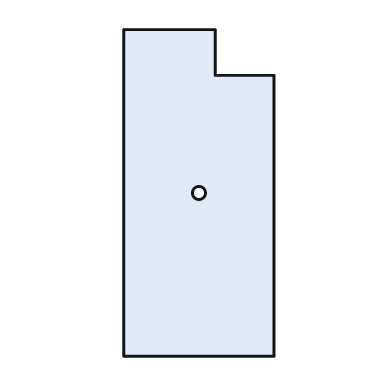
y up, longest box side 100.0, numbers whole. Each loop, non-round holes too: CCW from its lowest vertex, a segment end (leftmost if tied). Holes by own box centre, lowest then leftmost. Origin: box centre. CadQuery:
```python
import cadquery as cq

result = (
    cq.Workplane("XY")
    .moveTo(-23.0, -50.0)
    .lineTo(23.0, -50.0)
    .lineTo(23.0, 36.0)
    .lineTo(5.0, 36.0)
    .lineTo(5.0, 50.0)
    .lineTo(-23.0, 50.0)
    .close()
    .moveTo(0.0, 0.0)
    .circle(2.0)
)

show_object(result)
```